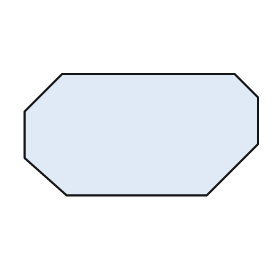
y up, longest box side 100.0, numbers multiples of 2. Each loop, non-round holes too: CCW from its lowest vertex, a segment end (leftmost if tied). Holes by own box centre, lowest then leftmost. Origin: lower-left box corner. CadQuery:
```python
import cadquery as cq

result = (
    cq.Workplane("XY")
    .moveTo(18.0, 0.0)
    .lineTo(78.0, 0.0)
    .lineTo(100.0, 22.0)
    .lineTo(100.0, 42.0)
    .lineTo(90.0, 52.0)
    .lineTo(16.0, 52.0)
    .lineTo(0.0, 36.0)
    .lineTo(0.0, 16.0)
    .close()
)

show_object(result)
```